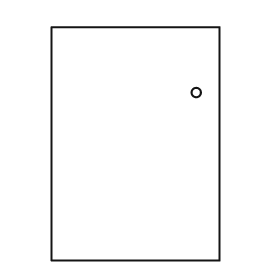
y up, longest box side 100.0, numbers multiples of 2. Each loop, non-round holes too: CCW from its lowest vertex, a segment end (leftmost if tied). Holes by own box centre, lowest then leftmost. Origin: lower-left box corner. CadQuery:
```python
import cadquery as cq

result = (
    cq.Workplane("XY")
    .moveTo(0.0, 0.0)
    .lineTo(72.0, 0.0)
    .lineTo(72.0, 100.0)
    .lineTo(0.0, 100.0)
    .close()
    .moveTo(62.0, 72.0)
    .circle(2.0)
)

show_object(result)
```